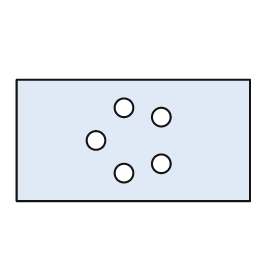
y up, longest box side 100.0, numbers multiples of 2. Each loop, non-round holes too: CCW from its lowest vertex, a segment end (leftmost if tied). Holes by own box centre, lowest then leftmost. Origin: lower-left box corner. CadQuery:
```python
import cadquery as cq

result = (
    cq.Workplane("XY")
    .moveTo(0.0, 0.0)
    .lineTo(100.0, 0.0)
    .lineTo(100.0, 52.0)
    .lineTo(0.0, 52.0)
    .close()
    .moveTo(46.0, 12.0)
    .circle(4.0)
    .moveTo(62.0, 16.0)
    .circle(4.0)
    .moveTo(34.0, 26.0)
    .circle(4.0)
    .moveTo(62.0, 36.0)
    .circle(4.0)
    .moveTo(46.0, 40.0)
    .circle(4.0)
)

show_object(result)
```